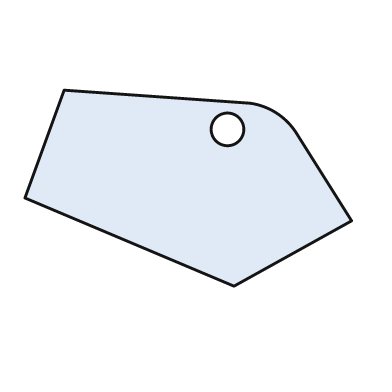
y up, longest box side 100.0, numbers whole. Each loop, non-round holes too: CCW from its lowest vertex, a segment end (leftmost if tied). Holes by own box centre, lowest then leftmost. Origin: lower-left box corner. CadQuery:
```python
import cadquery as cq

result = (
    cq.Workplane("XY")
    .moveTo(64.0, 0.0)
    .lineTo(100.0, 20.0)
    .lineTo(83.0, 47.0)
    .threePointArc((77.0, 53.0), (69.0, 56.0))
    .lineTo(12.0, 60.0)
    .lineTo(0.0, 27.0)
    .close()
    .moveTo(62.0, 48.0)
    .circle(5.0)
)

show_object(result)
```